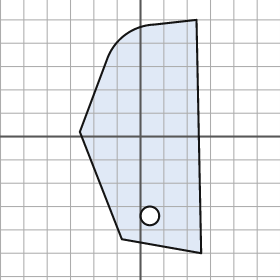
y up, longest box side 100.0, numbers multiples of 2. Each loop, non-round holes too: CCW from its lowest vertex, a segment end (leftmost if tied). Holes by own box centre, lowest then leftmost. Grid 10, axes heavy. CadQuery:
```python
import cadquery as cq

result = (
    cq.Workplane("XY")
    .moveTo(26.0, -50.0)
    .lineTo(24.0, 50.0)
    .lineTo(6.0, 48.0)
    .threePointArc((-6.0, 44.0), (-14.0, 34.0))
    .lineTo(-26.0, 2.0)
    .lineTo(-8.0, -44.0)
    .close()
    .moveTo(4.0, -34.0)
    .circle(4.0)
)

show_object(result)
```